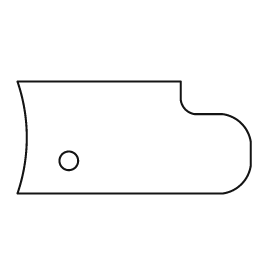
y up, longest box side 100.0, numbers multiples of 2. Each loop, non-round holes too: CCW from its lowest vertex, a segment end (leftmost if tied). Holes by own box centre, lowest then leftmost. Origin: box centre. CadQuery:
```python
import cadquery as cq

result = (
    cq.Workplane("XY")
    .moveTo(-50.0, -24.0)
    .lineTo(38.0, -24.0)
    .threePointArc((46.0, -20.0), (50.0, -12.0))
    .lineTo(50.0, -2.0)
    .threePointArc((46.0, 6.0), (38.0, 10.0))
    .lineTo(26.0, 10.0)
    .threePointArc((22.0, 12.0), (20.0, 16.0))
    .lineTo(20.0, 24.0)
    .lineTo(-50.0, 24.0)
    .threePointArc((-46.0, 0.0), (-50.0, -24.0))
    .close()
    .moveTo(-28.0, -10.0)
    .circle(4.0)
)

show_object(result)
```